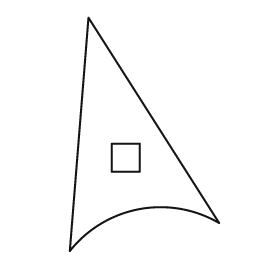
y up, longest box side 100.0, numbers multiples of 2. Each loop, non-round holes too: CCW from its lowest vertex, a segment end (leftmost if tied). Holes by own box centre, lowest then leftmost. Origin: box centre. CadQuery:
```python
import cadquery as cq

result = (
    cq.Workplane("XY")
    .moveTo(-32.0, -50.0)
    .threePointArc((-2.0, -32.0), (32.0, -38.0))
    .lineTo(-24.0, 50.0)
    .close()
    .moveTo(-14.0, -16.0)
    .lineTo(-2.0, -16.0)
    .lineTo(-2.0, -4.0)
    .lineTo(-14.0, -4.0)
    .close()
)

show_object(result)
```